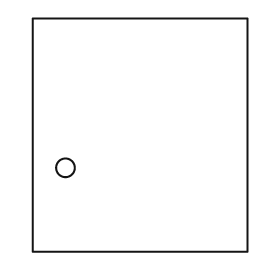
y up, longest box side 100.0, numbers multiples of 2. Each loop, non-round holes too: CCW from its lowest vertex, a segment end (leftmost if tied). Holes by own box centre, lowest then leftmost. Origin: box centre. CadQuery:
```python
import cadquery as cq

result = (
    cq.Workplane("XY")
    .moveTo(-46.0, -50.0)
    .lineTo(46.0, -50.0)
    .lineTo(46.0, 50.0)
    .lineTo(-46.0, 50.0)
    .close()
    .moveTo(-32.0, -14.0)
    .circle(4.0)
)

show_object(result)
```